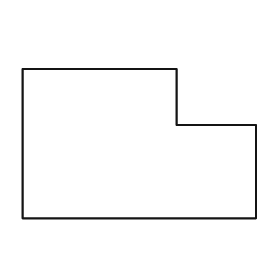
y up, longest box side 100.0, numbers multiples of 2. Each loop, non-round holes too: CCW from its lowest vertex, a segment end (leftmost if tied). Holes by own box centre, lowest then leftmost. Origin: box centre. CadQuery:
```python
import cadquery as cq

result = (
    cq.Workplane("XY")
    .moveTo(-50.0, -32.0)
    .lineTo(50.0, -32.0)
    .lineTo(50.0, 8.0)
    .lineTo(16.0, 8.0)
    .lineTo(16.0, 32.0)
    .lineTo(-50.0, 32.0)
    .close()
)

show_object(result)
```